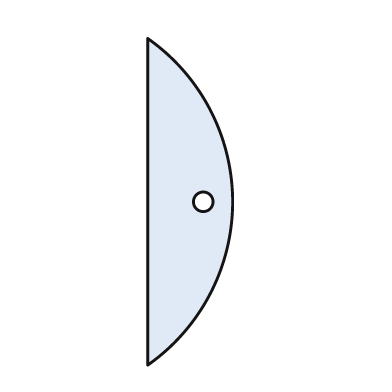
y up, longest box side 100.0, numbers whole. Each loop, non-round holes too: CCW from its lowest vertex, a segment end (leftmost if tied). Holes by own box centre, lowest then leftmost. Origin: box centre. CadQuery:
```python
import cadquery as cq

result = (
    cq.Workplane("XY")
    .moveTo(-13.0, -50.0)
    .threePointArc((13.0, 0.0), (-13.0, 50.0))
    .close()
    .moveTo(4.0, 0.0)
    .circle(3.0)
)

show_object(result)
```